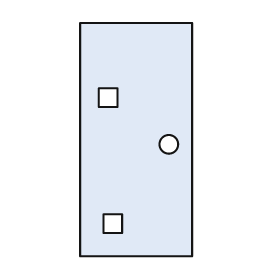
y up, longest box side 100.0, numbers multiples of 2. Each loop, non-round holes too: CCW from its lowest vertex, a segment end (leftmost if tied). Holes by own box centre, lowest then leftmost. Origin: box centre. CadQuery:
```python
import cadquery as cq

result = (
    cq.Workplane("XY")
    .moveTo(-24.0, -50.0)
    .lineTo(24.0, -50.0)
    .lineTo(24.0, 50.0)
    .lineTo(-24.0, 50.0)
    .close()
    .moveTo(-14.0, -40.0)
    .lineTo(-6.0, -40.0)
    .lineTo(-6.0, -32.0)
    .lineTo(-14.0, -32.0)
    .close()
    .moveTo(14.0, -2.0)
    .circle(4.0)
    .moveTo(-16.0, 14.0)
    .lineTo(-8.0, 14.0)
    .lineTo(-8.0, 22.0)
    .lineTo(-16.0, 22.0)
    .close()
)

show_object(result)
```